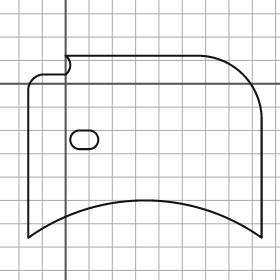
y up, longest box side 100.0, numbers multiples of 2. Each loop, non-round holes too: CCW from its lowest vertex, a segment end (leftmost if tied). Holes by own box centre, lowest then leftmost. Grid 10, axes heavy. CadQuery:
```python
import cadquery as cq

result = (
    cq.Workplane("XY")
    .moveTo(-16.0, -66.0)
    .threePointArc((34.0, -50.0), (84.0, -66.0))
    .lineTo(84.0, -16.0)
    .threePointArc((76.0, 4.0), (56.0, 12.0))
    .lineTo(0.0, 12.0)
    .threePointArc((2.0, 8.0), (0.0, 4.0))
    .lineTo(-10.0, 4.0)
    .threePointArc((-14.0, 2.0), (-16.0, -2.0))
    .close()
    .moveTo(6.0, -28.0)
    .lineTo(10.0, -28.0)
    .threePointArc((14.0, -24.0), (10.0, -20.0))
    .lineTo(6.0, -20.0)
    .threePointArc((2.0, -24.0), (6.0, -28.0))
    .close()
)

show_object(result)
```